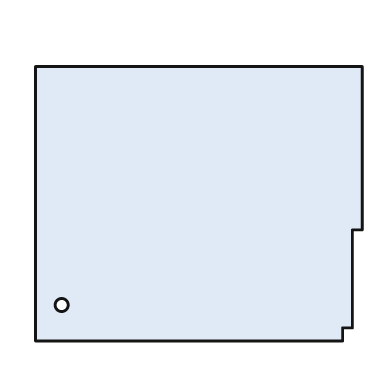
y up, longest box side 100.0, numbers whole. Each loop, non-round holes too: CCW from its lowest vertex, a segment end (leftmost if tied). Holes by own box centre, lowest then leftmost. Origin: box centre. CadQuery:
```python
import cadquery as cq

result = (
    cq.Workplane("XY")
    .moveTo(-50.0, -42.0)
    .lineTo(44.0, -42.0)
    .lineTo(44.0, -38.0)
    .lineTo(47.0, -38.0)
    .lineTo(47.0, -8.0)
    .lineTo(50.0, -8.0)
    .lineTo(50.0, 42.0)
    .lineTo(-50.0, 42.0)
    .close()
    .moveTo(-42.0, -31.0)
    .circle(2.0)
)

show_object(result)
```